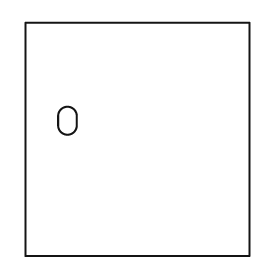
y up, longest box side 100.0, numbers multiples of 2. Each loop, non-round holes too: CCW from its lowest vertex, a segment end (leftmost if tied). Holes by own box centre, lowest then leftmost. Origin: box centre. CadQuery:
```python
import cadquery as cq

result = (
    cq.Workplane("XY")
    .moveTo(-48.0, -50.0)
    .lineTo(48.0, -50.0)
    .lineTo(48.0, 50.0)
    .lineTo(-48.0, 50.0)
    .close()
    .moveTo(-34.0, 6.0)
    .threePointArc((-30.0, 2.0), (-26.0, 6.0))
    .lineTo(-26.0, 10.0)
    .threePointArc((-30.0, 14.0), (-34.0, 10.0))
    .close()
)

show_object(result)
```